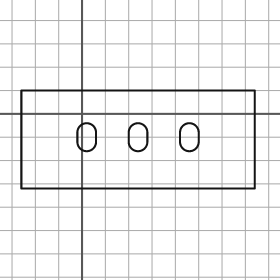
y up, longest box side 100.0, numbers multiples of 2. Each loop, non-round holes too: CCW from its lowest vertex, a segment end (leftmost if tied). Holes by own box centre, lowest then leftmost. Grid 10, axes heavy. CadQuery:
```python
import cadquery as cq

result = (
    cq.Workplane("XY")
    .moveTo(-26.0, -32.0)
    .lineTo(74.0, -32.0)
    .lineTo(74.0, 10.0)
    .lineTo(-26.0, 10.0)
    .close()
    .moveTo(-2.0, -12.0)
    .threePointArc((2.0, -16.0), (6.0, -12.0))
    .lineTo(6.0, -8.0)
    .threePointArc((2.0, -4.0), (-2.0, -8.0))
    .close()
    .moveTo(20.0, -12.0)
    .threePointArc((24.0, -16.0), (28.0, -12.0))
    .lineTo(28.0, -8.0)
    .threePointArc((24.0, -4.0), (20.0, -8.0))
    .close()
    .moveTo(42.0, -12.0)
    .threePointArc((46.0, -16.0), (50.0, -12.0))
    .lineTo(50.0, -8.0)
    .threePointArc((46.0, -4.0), (42.0, -8.0))
    .close()
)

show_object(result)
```